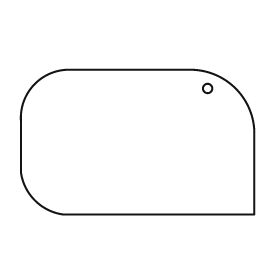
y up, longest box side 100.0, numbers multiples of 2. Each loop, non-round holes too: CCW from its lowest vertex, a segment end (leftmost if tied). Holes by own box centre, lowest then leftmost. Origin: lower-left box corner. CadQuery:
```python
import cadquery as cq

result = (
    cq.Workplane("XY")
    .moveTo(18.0, 0.0)
    .lineTo(100.0, 0.0)
    .lineTo(100.0, 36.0)
    .threePointArc((92.0, 54.0), (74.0, 62.0))
    .lineTo(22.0, 62.0)
    .threePointArc((6.0, 56.0), (0.0, 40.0))
    .lineTo(0.0, 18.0)
    .threePointArc((6.0, 6.0), (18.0, 0.0))
    .close()
    .moveTo(80.0, 54.0)
    .circle(2.0)
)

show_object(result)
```